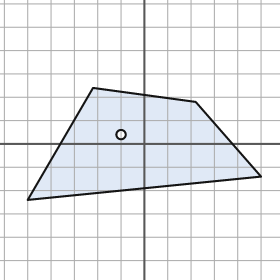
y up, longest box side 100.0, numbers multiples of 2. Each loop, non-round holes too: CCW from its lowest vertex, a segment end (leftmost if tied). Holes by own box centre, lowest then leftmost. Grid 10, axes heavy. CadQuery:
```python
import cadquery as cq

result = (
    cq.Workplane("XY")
    .moveTo(-50.0, -24.0)
    .lineTo(50.0, -14.0)
    .lineTo(22.0, 18.0)
    .lineTo(-22.0, 24.0)
    .close()
    .moveTo(-10.0, 4.0)
    .circle(2.0)
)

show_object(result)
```